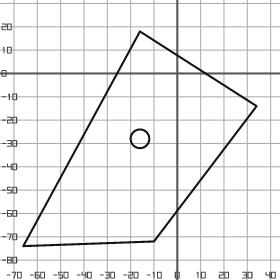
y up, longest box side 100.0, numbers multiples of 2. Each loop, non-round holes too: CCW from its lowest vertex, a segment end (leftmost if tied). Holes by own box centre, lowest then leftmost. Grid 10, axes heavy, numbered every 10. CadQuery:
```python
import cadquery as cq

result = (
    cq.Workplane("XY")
    .moveTo(-66.0, -74.0)
    .lineTo(-10.0, -72.0)
    .lineTo(34.0, -14.0)
    .lineTo(-16.0, 18.0)
    .close()
    .moveTo(-16.0, -28.0)
    .circle(4.0)
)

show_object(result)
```